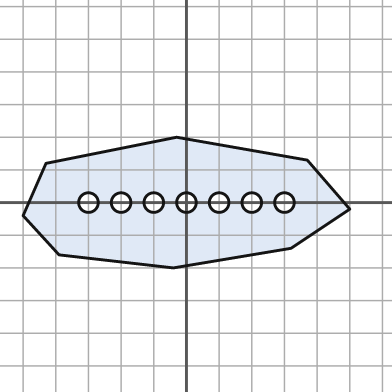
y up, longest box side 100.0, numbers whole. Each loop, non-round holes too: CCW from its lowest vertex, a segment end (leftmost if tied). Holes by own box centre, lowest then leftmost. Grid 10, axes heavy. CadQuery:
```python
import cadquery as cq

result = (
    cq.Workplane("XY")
    .moveTo(-4.0, -20.0)
    .lineTo(32.0, -14.0)
    .lineTo(50.0, -2.0)
    .lineTo(37.0, 13.0)
    .lineTo(-3.0, 20.0)
    .lineTo(-43.0, 12.0)
    .lineTo(-50.0, -4.0)
    .lineTo(-39.0, -16.0)
    .close()
    .moveTo(-30.0, 0.0)
    .circle(3.0)
    .moveTo(-20.0, 0.0)
    .circle(3.0)
    .moveTo(-10.0, 0.0)
    .circle(3.0)
    .moveTo(0.0, 0.0)
    .circle(3.0)
    .moveTo(10.0, 0.0)
    .circle(3.0)
    .moveTo(20.0, 0.0)
    .circle(3.0)
    .moveTo(30.0, 0.0)
    .circle(3.0)
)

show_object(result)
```